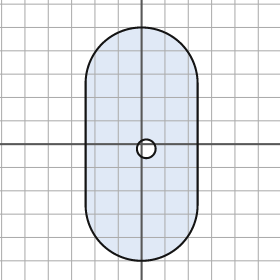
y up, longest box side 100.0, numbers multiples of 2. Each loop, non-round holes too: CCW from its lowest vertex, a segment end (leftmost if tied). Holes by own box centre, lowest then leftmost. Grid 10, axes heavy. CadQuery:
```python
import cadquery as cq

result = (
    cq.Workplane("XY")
    .moveTo(-24.0, -26.0)
    .threePointArc((0.0, -50.0), (24.0, -26.0))
    .lineTo(24.0, 26.0)
    .threePointArc((0.0, 50.0), (-24.0, 26.0))
    .close()
    .moveTo(2.0, -2.0)
    .circle(4.0)
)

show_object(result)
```